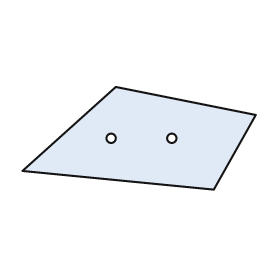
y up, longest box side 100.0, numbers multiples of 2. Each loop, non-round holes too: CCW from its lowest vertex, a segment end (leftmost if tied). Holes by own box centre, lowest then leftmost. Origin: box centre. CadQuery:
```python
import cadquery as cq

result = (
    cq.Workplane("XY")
    .moveTo(32.0, -22.0)
    .lineTo(50.0, 10.0)
    .lineTo(-10.0, 22.0)
    .lineTo(-50.0, -14.0)
    .close()
    .moveTo(-12.0, 0.0)
    .circle(2.0)
    .moveTo(14.0, 0.0)
    .circle(2.0)
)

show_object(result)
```